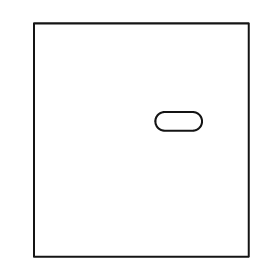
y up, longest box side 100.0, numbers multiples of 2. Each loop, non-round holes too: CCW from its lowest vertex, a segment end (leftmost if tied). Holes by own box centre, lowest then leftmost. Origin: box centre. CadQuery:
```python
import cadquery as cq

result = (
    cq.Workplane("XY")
    .moveTo(-46.0, -50.0)
    .lineTo(46.0, -50.0)
    .lineTo(46.0, 50.0)
    .lineTo(-46.0, 50.0)
    .close()
    .moveTo(10.0, 4.0)
    .lineTo(22.0, 4.0)
    .threePointArc((26.0, 8.0), (22.0, 12.0))
    .lineTo(10.0, 12.0)
    .threePointArc((6.0, 8.0), (10.0, 4.0))
    .close()
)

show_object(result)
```